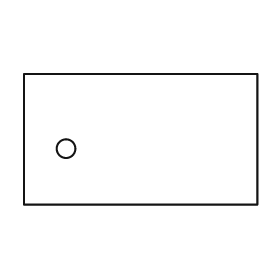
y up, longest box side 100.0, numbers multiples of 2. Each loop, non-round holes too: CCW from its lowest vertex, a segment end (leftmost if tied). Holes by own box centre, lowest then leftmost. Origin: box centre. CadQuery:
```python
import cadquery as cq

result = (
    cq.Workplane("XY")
    .moveTo(-50.0, -28.0)
    .lineTo(50.0, -28.0)
    .lineTo(50.0, 28.0)
    .lineTo(-50.0, 28.0)
    .close()
    .moveTo(-32.0, -4.0)
    .circle(4.0)
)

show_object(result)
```